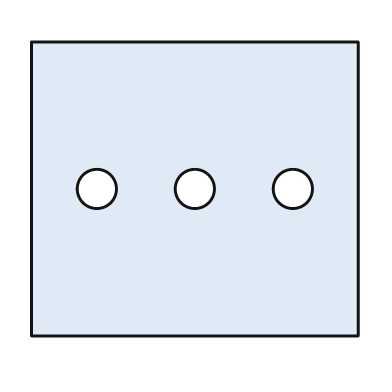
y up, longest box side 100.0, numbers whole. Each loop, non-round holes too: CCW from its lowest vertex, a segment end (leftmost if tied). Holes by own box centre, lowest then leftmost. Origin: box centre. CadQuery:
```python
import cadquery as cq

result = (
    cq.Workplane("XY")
    .moveTo(-50.0, -45.0)
    .lineTo(50.0, -45.0)
    .lineTo(50.0, 45.0)
    .lineTo(-50.0, 45.0)
    .close()
    .moveTo(-30.0, 0.0)
    .circle(6.0)
    .moveTo(0.0, 0.0)
    .circle(6.0)
    .moveTo(30.0, 0.0)
    .circle(6.0)
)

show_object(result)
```